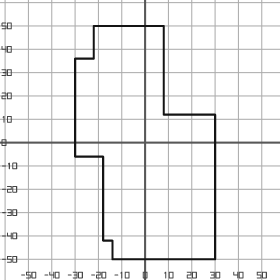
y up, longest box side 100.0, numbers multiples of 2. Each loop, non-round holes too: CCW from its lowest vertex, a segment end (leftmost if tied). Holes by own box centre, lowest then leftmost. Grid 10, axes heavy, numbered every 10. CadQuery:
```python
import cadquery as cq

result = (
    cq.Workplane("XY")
    .moveTo(-14.0, -50.0)
    .lineTo(30.0, -50.0)
    .lineTo(30.0, 12.0)
    .lineTo(8.0, 12.0)
    .lineTo(8.0, 50.0)
    .lineTo(-22.0, 50.0)
    .lineTo(-22.0, 36.0)
    .lineTo(-30.0, 36.0)
    .lineTo(-30.0, -6.0)
    .lineTo(-18.0, -6.0)
    .lineTo(-18.0, -42.0)
    .lineTo(-14.0, -42.0)
    .close()
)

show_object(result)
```